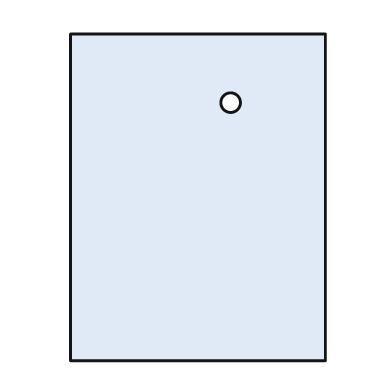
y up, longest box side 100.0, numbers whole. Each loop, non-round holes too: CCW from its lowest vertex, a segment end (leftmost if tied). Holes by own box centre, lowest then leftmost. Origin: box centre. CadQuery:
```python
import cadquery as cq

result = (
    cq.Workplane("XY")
    .moveTo(-39.0, -50.0)
    .lineTo(39.0, -50.0)
    .lineTo(39.0, 50.0)
    .lineTo(-39.0, 50.0)
    .close()
    .moveTo(10.0, 29.0)
    .circle(3.0)
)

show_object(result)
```